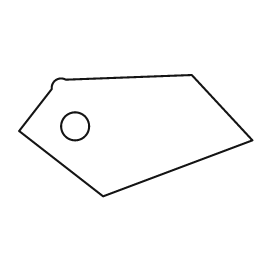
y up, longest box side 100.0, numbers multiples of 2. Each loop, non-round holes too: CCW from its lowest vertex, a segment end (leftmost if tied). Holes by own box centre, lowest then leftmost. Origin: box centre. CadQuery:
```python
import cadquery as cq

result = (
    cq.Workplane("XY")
    .moveTo(-14.0, -26.0)
    .lineTo(50.0, -2.0)
    .lineTo(24.0, 26.0)
    .lineTo(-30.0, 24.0)
    .threePointArc((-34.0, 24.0), (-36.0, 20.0))
    .lineTo(-50.0, 2.0)
    .close()
    .moveTo(-26.0, 4.0)
    .circle(6.0)
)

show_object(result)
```